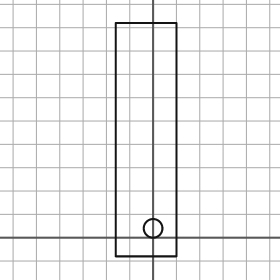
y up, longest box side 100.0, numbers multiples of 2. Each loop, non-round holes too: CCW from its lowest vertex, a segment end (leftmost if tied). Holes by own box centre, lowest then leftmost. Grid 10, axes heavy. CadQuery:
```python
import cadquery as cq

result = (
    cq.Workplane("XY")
    .moveTo(-16.0, -8.0)
    .lineTo(10.0, -8.0)
    .lineTo(10.0, 92.0)
    .lineTo(-16.0, 92.0)
    .close()
    .moveTo(0.0, 4.0)
    .circle(4.0)
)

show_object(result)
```